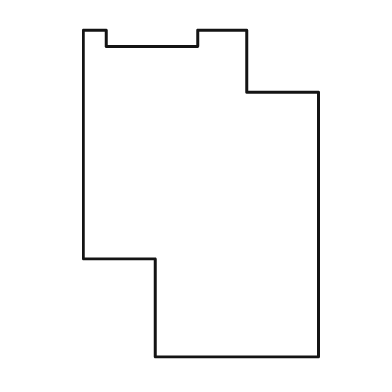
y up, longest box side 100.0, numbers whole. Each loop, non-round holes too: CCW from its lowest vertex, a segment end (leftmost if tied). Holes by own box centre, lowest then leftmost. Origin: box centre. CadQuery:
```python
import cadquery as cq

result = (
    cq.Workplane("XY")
    .moveTo(-14.0, -50.0)
    .lineTo(36.0, -50.0)
    .lineTo(36.0, 31.0)
    .lineTo(14.0, 31.0)
    .lineTo(14.0, 50.0)
    .lineTo(-1.0, 50.0)
    .lineTo(-1.0, 45.0)
    .lineTo(-29.0, 45.0)
    .lineTo(-29.0, 50.0)
    .lineTo(-36.0, 50.0)
    .lineTo(-36.0, -20.0)
    .lineTo(-14.0, -20.0)
    .close()
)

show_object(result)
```